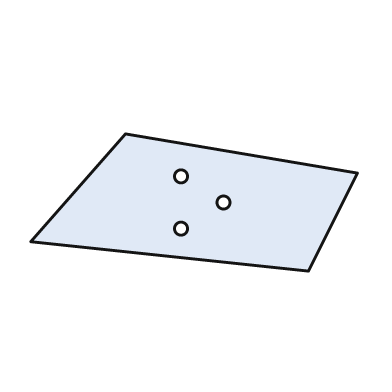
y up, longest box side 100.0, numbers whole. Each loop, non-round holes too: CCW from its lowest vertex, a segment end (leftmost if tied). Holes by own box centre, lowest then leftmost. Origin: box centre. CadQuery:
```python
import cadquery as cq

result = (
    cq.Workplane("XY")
    .moveTo(35.0, -21.0)
    .lineTo(50.0, 9.0)
    .lineTo(-21.0, 21.0)
    .lineTo(-50.0, -12.0)
    .close()
    .moveTo(-4.0, -8.0)
    .circle(2.0)
    .moveTo(9.0, 0.0)
    .circle(2.0)
    .moveTo(-4.0, 8.0)
    .circle(2.0)
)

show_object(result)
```